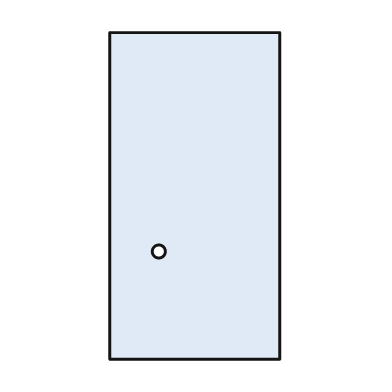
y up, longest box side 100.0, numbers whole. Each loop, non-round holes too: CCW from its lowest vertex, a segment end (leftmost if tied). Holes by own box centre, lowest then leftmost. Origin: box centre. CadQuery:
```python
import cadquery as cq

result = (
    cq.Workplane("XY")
    .moveTo(-26.0, -50.0)
    .lineTo(26.0, -50.0)
    .lineTo(26.0, 50.0)
    .lineTo(-26.0, 50.0)
    .close()
    .moveTo(-11.0, -17.0)
    .circle(2.0)
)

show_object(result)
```